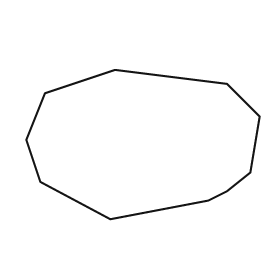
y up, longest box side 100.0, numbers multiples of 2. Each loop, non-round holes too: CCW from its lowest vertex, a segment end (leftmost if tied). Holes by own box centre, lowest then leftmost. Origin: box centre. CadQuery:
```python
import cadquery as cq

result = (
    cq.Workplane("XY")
    .moveTo(-14.0, -32.0)
    .lineTo(28.0, -24.0)
    .lineTo(36.0, -20.0)
    .lineTo(46.0, -12.0)
    .lineTo(50.0, 12.0)
    .lineTo(36.0, 26.0)
    .lineTo(-12.0, 32.0)
    .lineTo(-42.0, 22.0)
    .lineTo(-50.0, 2.0)
    .lineTo(-44.0, -16.0)
    .close()
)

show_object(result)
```